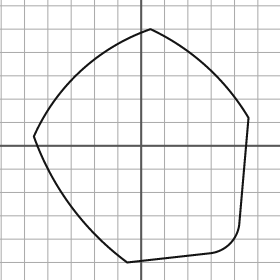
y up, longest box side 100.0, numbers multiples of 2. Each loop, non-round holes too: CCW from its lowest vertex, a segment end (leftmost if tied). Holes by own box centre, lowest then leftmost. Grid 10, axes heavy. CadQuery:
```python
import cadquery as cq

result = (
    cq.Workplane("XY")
    .moveTo(-6.0, -50.0)
    .lineTo(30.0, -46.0)
    .threePointArc((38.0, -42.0), (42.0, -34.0))
    .lineTo(46.0, 12.0)
    .threePointArc((28.0, 34.0), (4.0, 50.0))
    .threePointArc((-26.0, 32.0), (-46.0, 4.0))
    .threePointArc((-30.0, -26.0), (-6.0, -50.0))
    .close()
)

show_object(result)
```